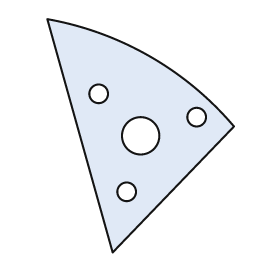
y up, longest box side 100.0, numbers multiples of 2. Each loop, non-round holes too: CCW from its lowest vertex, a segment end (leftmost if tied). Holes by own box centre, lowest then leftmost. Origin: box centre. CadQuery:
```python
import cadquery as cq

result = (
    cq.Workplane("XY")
    .moveTo(-12.0, -50.0)
    .lineTo(40.0, 4.0)
    .threePointArc((4.0, 34.0), (-40.0, 50.0))
    .close()
    .moveTo(-6.0, -24.0)
    .circle(4.0)
    .moveTo(0.0, 0.0)
    .circle(8.0)
    .moveTo(24.0, 8.0)
    .circle(4.0)
    .moveTo(-18.0, 18.0)
    .circle(4.0)
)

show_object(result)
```